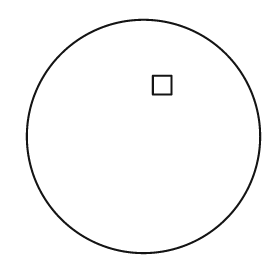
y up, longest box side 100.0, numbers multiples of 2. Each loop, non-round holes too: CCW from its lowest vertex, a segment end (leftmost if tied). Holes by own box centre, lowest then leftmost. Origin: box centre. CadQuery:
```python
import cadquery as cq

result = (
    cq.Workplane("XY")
    .moveTo(0.0, 0.0)
    .circle(50.0)
    .moveTo(4.0, 18.0)
    .lineTo(12.0, 18.0)
    .lineTo(12.0, 26.0)
    .lineTo(4.0, 26.0)
    .close()
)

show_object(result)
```